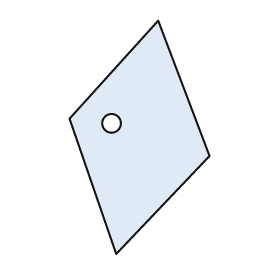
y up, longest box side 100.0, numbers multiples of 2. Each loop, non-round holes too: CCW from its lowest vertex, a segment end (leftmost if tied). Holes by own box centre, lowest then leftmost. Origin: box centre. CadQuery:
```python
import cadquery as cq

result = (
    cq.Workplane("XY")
    .moveTo(-10.0, -50.0)
    .lineTo(30.0, -8.0)
    .lineTo(8.0, 50.0)
    .lineTo(-30.0, 8.0)
    .close()
    .moveTo(-12.0, 6.0)
    .circle(4.0)
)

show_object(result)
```